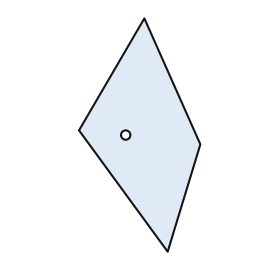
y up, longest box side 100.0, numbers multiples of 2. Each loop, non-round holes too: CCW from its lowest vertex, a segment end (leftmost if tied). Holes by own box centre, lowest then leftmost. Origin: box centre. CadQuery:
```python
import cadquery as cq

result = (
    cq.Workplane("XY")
    .moveTo(12.0, -50.0)
    .lineTo(26.0, -4.0)
    .lineTo(2.0, 50.0)
    .lineTo(-26.0, 2.0)
    .close()
    .moveTo(-6.0, 0.0)
    .circle(2.0)
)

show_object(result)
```